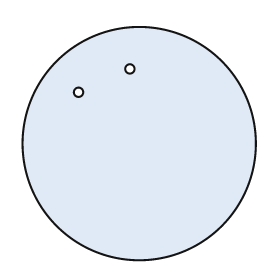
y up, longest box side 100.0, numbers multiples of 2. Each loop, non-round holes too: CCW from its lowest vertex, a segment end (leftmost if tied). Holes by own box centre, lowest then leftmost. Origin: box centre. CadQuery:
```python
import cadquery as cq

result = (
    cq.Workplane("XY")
    .moveTo(0.0, 0.0)
    .circle(50.0)
    .moveTo(-26.0, 22.0)
    .circle(2.0)
    .moveTo(-4.0, 32.0)
    .circle(2.0)
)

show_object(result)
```